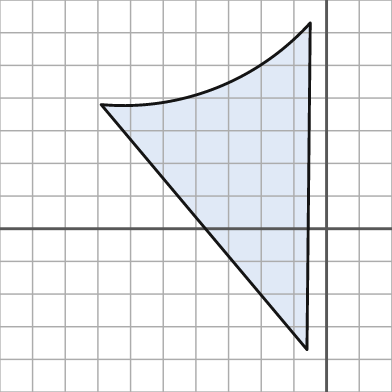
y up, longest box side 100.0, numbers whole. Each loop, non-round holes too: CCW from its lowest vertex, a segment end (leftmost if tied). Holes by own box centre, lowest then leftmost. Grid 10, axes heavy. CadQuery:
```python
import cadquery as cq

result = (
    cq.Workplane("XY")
    .moveTo(-6.0, -37.0)
    .lineTo(-5.0, 63.0)
    .threePointArc((-34.0, 43.0), (-69.0, 38.0))
    .close()
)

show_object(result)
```